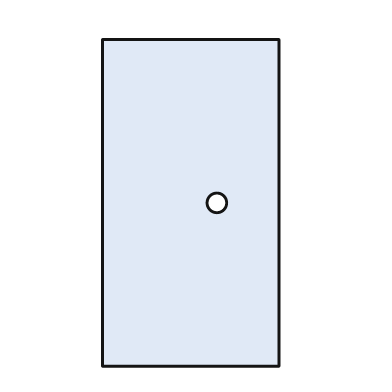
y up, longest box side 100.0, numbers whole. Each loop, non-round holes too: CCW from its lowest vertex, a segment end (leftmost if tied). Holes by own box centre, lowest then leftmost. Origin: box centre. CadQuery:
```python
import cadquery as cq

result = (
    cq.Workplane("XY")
    .moveTo(-27.0, -50.0)
    .lineTo(27.0, -50.0)
    .lineTo(27.0, 50.0)
    .lineTo(-27.0, 50.0)
    .close()
    .moveTo(8.0, 0.0)
    .circle(3.0)
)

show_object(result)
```